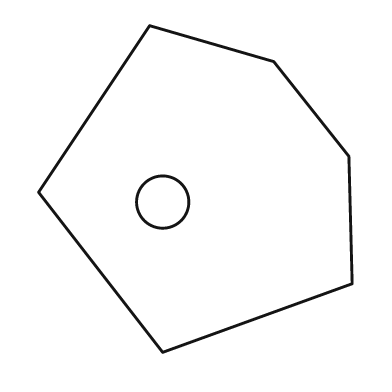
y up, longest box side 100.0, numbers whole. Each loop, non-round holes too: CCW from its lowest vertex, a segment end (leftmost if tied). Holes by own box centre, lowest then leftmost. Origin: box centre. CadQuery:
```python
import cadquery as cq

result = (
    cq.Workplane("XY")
    .moveTo(-10.0, -50.0)
    .lineTo(48.0, -29.0)
    .lineTo(47.0, 10.0)
    .lineTo(24.0, 39.0)
    .lineTo(-14.0, 50.0)
    .lineTo(-48.0, -1.0)
    .close()
    .moveTo(-10.0, -4.0)
    .circle(8.0)
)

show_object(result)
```